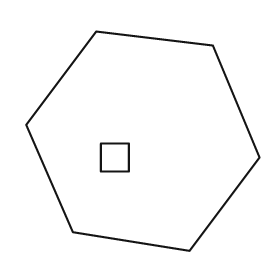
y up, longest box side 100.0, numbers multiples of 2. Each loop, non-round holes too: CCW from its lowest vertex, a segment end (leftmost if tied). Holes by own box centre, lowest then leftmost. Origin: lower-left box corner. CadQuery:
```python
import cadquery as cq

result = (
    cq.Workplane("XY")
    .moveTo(70.0, 0.0)
    .lineTo(100.0, 40.0)
    .lineTo(80.0, 88.0)
    .lineTo(30.0, 94.0)
    .lineTo(0.0, 54.0)
    .lineTo(20.0, 8.0)
    .close()
    .moveTo(32.0, 34.0)
    .lineTo(44.0, 34.0)
    .lineTo(44.0, 46.0)
    .lineTo(32.0, 46.0)
    .close()
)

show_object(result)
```